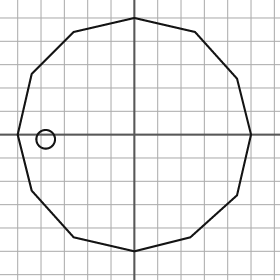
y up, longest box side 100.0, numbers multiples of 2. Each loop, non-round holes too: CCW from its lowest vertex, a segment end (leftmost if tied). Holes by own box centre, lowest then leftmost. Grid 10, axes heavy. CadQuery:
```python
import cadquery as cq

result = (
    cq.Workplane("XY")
    .moveTo(0.0, -50.0)
    .lineTo(24.0, -44.0)
    .lineTo(44.0, -26.0)
    .lineTo(50.0, 0.0)
    .lineTo(44.0, 24.0)
    .lineTo(26.0, 44.0)
    .lineTo(0.0, 50.0)
    .lineTo(-26.0, 44.0)
    .lineTo(-44.0, 26.0)
    .lineTo(-50.0, 0.0)
    .lineTo(-44.0, -24.0)
    .lineTo(-26.0, -44.0)
    .close()
    .moveTo(-38.0, -2.0)
    .circle(4.0)
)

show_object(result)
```